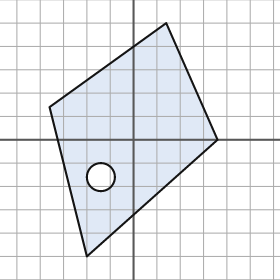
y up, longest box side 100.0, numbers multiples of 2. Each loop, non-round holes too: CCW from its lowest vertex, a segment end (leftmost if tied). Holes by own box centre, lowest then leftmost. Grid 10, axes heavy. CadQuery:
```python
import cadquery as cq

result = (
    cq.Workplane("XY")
    .moveTo(-20.0, -50.0)
    .lineTo(36.0, 0.0)
    .lineTo(14.0, 50.0)
    .lineTo(-36.0, 14.0)
    .close()
    .moveTo(-14.0, -16.0)
    .circle(6.0)
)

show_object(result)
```